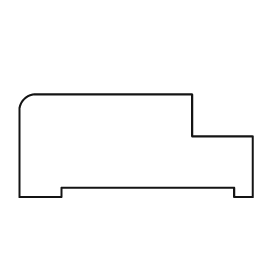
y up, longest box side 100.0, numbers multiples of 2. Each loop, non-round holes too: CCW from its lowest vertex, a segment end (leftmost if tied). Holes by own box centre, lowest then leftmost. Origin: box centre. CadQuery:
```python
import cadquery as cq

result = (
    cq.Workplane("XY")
    .moveTo(-50.0, -22.0)
    .lineTo(-32.0, -22.0)
    .lineTo(-32.0, -18.0)
    .lineTo(42.0, -18.0)
    .lineTo(42.0, -22.0)
    .lineTo(50.0, -22.0)
    .lineTo(50.0, 4.0)
    .lineTo(24.0, 4.0)
    .lineTo(24.0, 22.0)
    .lineTo(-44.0, 22.0)
    .threePointArc((-48.0, 20.0), (-50.0, 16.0))
    .close()
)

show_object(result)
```